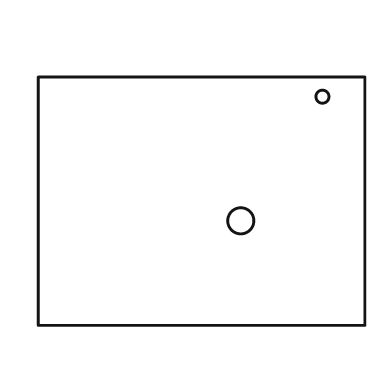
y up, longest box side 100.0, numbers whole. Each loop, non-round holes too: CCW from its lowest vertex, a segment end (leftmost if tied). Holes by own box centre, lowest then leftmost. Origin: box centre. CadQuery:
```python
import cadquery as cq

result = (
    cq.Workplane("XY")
    .moveTo(-50.0, -38.0)
    .lineTo(50.0, -38.0)
    .lineTo(50.0, 38.0)
    .lineTo(-50.0, 38.0)
    .close()
    .moveTo(12.0, -6.0)
    .circle(4.0)
    .moveTo(37.0, 32.0)
    .circle(2.0)
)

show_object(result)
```